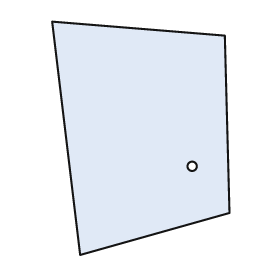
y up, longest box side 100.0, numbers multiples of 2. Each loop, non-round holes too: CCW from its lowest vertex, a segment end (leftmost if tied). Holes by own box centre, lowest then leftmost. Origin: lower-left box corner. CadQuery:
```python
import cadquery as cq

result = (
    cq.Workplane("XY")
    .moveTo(12.0, 0.0)
    .lineTo(76.0, 18.0)
    .lineTo(74.0, 94.0)
    .lineTo(0.0, 100.0)
    .close()
    .moveTo(60.0, 38.0)
    .circle(2.0)
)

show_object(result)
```